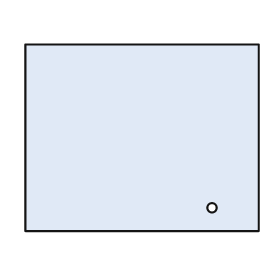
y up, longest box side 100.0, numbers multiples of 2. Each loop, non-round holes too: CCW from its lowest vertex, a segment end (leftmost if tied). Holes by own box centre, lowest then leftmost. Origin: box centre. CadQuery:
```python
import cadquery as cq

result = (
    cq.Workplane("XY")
    .moveTo(-50.0, -40.0)
    .lineTo(50.0, -40.0)
    .lineTo(50.0, 40.0)
    .lineTo(-50.0, 40.0)
    .close()
    .moveTo(30.0, -30.0)
    .circle(2.0)
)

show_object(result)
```